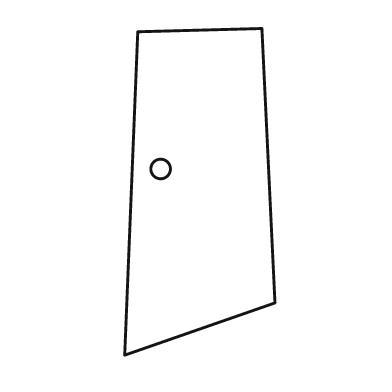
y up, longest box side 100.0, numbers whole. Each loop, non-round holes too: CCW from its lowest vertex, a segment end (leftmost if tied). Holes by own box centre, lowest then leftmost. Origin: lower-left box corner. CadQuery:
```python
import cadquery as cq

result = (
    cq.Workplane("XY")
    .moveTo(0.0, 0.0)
    .lineTo(46.0, 16.0)
    .lineTo(42.0, 100.0)
    .lineTo(4.0, 99.0)
    .close()
    .moveTo(11.0, 57.0)
    .circle(3.0)
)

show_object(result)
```